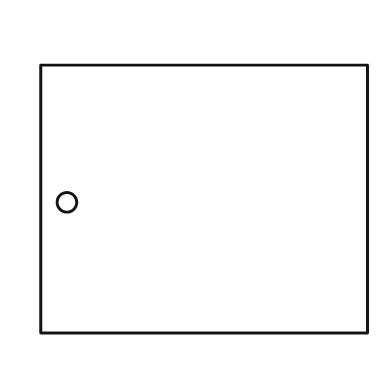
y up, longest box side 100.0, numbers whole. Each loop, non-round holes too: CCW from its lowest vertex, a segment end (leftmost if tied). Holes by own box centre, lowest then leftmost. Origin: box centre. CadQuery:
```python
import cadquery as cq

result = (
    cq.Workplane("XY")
    .moveTo(-50.0, -41.0)
    .lineTo(50.0, -41.0)
    .lineTo(50.0, 41.0)
    .lineTo(-50.0, 41.0)
    .close()
    .moveTo(-42.0, -1.0)
    .circle(3.0)
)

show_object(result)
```